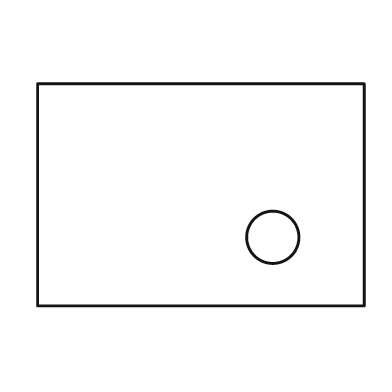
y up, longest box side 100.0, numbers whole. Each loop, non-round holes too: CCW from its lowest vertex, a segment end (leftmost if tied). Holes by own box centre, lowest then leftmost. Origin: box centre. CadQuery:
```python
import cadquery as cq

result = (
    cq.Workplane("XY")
    .moveTo(-50.0, -34.0)
    .lineTo(50.0, -34.0)
    .lineTo(50.0, 34.0)
    .lineTo(-50.0, 34.0)
    .close()
    .moveTo(22.0, -13.0)
    .circle(8.0)
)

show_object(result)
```